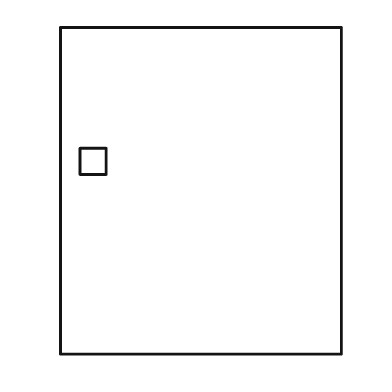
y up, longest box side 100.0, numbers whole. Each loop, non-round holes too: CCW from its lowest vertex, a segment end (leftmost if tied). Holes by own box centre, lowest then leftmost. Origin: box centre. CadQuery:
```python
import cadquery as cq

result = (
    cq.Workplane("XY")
    .moveTo(-43.0, -50.0)
    .lineTo(43.0, -50.0)
    .lineTo(43.0, 50.0)
    .lineTo(-43.0, 50.0)
    .close()
    .moveTo(-37.0, 5.0)
    .lineTo(-29.0, 5.0)
    .lineTo(-29.0, 13.0)
    .lineTo(-37.0, 13.0)
    .close()
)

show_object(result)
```